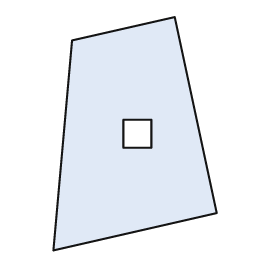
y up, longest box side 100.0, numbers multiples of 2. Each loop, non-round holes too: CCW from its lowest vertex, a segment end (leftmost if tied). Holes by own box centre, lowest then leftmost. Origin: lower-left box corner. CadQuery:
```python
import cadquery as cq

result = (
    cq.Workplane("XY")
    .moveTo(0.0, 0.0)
    .lineTo(70.0, 16.0)
    .lineTo(52.0, 100.0)
    .lineTo(8.0, 90.0)
    .close()
    .moveTo(30.0, 44.0)
    .lineTo(42.0, 44.0)
    .lineTo(42.0, 56.0)
    .lineTo(30.0, 56.0)
    .close()
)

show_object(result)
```